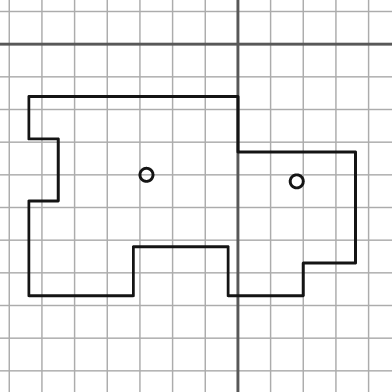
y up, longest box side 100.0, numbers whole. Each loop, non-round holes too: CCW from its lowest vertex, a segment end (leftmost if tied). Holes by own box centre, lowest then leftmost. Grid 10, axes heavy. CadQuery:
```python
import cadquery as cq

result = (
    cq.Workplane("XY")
    .moveTo(-64.0, -77.0)
    .lineTo(-32.0, -77.0)
    .lineTo(-32.0, -62.0)
    .lineTo(-3.0, -62.0)
    .lineTo(-3.0, -77.0)
    .lineTo(20.0, -77.0)
    .lineTo(20.0, -67.0)
    .lineTo(36.0, -67.0)
    .lineTo(36.0, -33.0)
    .lineTo(0.0, -33.0)
    .lineTo(0.0, -16.0)
    .lineTo(-64.0, -16.0)
    .lineTo(-64.0, -29.0)
    .lineTo(-55.0, -29.0)
    .lineTo(-55.0, -48.0)
    .lineTo(-64.0, -48.0)
    .close()
    .moveTo(18.0, -42.0)
    .circle(2.0)
    .moveTo(-28.0, -40.0)
    .circle(2.0)
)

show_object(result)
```